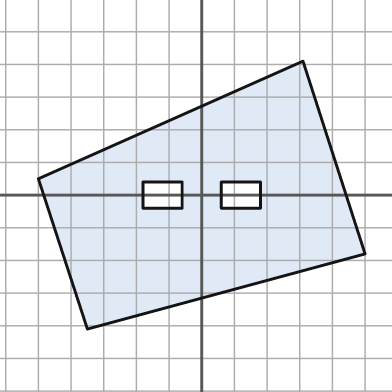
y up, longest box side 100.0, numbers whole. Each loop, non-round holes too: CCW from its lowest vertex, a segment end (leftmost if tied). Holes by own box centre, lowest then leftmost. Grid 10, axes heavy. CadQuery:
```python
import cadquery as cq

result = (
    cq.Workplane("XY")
    .moveTo(-35.0, -41.0)
    .lineTo(50.0, -18.0)
    .lineTo(31.0, 41.0)
    .lineTo(-50.0, 5.0)
    .close()
    .moveTo(-18.0, -4.0)
    .lineTo(-6.0, -4.0)
    .lineTo(-6.0, 4.0)
    .lineTo(-18.0, 4.0)
    .close()
    .moveTo(6.0, -4.0)
    .lineTo(18.0, -4.0)
    .lineTo(18.0, 4.0)
    .lineTo(6.0, 4.0)
    .close()
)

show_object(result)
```